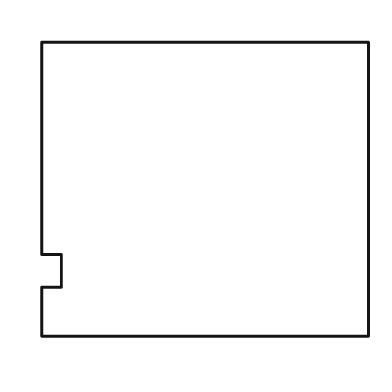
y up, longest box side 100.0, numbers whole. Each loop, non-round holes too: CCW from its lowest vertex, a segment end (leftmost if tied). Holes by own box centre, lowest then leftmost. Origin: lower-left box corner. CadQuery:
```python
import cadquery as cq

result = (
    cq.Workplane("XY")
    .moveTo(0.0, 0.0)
    .lineTo(100.0, 0.0)
    .lineTo(100.0, 90.0)
    .lineTo(0.0, 90.0)
    .lineTo(0.0, 25.0)
    .lineTo(6.0, 25.0)
    .lineTo(6.0, 15.0)
    .lineTo(0.0, 15.0)
    .close()
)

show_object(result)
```